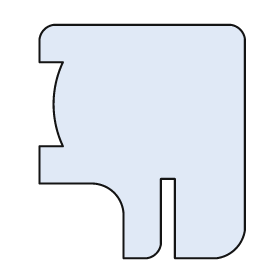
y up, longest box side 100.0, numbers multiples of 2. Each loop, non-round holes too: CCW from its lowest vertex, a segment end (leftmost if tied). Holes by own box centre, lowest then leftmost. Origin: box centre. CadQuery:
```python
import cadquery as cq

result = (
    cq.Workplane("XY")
    .moveTo(-8.0, -50.0)
    .lineTo(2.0, -50.0)
    .threePointArc((6.0, -48.0), (8.0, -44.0))
    .lineTo(8.0, -16.0)
    .lineTo(14.0, -16.0)
    .lineTo(14.0, -50.0)
    .lineTo(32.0, -50.0)
    .threePointArc((40.0, -46.0), (44.0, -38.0))
    .lineTo(44.0, 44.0)
    .threePointArc((42.0, 48.0), (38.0, 50.0))
    .lineTo(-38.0, 50.0)
    .threePointArc((-42.0, 48.0), (-44.0, 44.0))
    .lineTo(-44.0, 34.0)
    .lineTo(-34.0, 34.0)
    .threePointArc((-38.0, 16.0), (-34.0, -2.0))
    .lineTo(-44.0, -2.0)
    .lineTo(-44.0, -18.0)
    .lineTo(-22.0, -18.0)
    .threePointArc((-12.0, -22.0), (-8.0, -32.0))
    .close()
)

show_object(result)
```